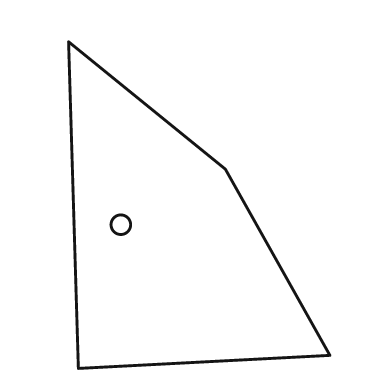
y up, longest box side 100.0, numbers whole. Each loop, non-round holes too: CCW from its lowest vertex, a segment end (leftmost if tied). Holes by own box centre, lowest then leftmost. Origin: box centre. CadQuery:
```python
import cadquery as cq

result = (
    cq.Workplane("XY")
    .moveTo(-37.0, -50.0)
    .lineTo(40.0, -46.0)
    .lineTo(8.0, 11.0)
    .lineTo(-40.0, 50.0)
    .close()
    .moveTo(-24.0, -6.0)
    .circle(3.0)
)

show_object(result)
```